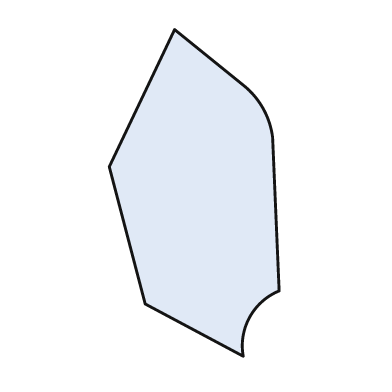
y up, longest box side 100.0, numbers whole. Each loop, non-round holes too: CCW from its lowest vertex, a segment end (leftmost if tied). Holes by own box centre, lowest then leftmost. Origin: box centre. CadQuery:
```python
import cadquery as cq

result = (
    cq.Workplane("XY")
    .moveTo(15.0, -50.0)
    .threePointArc((17.0, -38.0), (26.0, -30.0))
    .lineTo(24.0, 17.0)
    .threePointArc((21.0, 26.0), (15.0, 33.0))
    .lineTo(-6.0, 50.0)
    .lineTo(-26.0, 8.0)
    .lineTo(-15.0, -34.0)
    .close()
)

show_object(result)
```